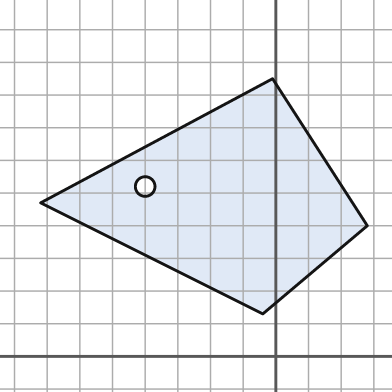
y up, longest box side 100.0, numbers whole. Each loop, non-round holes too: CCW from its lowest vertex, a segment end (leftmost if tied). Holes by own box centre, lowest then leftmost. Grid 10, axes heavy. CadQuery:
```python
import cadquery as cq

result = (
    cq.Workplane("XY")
    .moveTo(-4.0, 13.0)
    .lineTo(28.0, 40.0)
    .lineTo(-1.0, 85.0)
    .lineTo(-72.0, 47.0)
    .close()
    .moveTo(-40.0, 52.0)
    .circle(3.0)
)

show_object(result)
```